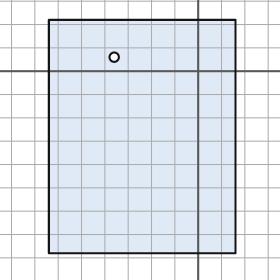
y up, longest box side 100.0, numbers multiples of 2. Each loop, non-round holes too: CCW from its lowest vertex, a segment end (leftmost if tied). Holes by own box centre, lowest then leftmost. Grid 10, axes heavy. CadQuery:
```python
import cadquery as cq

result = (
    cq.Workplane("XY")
    .moveTo(-64.0, -78.0)
    .lineTo(16.0, -78.0)
    .lineTo(16.0, 22.0)
    .lineTo(-64.0, 22.0)
    .close()
    .moveTo(-36.0, 6.0)
    .circle(2.0)
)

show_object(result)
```